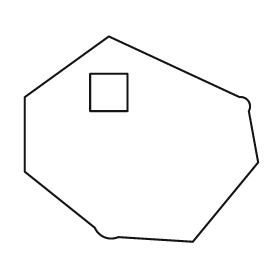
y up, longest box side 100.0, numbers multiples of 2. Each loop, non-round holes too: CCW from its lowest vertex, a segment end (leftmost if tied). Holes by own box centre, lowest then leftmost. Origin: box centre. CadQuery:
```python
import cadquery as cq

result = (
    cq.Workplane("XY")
    .moveTo(22.0, -44.0)
    .lineTo(50.0, -10.0)
    .lineTo(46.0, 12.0)
    .threePointArc((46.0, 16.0), (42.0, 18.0))
    .lineTo(-14.0, 44.0)
    .lineTo(-50.0, 18.0)
    .lineTo(-50.0, -14.0)
    .lineTo(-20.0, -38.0)
    .threePointArc((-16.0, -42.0), (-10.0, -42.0))
    .close()
    .moveTo(-22.0, 12.0)
    .lineTo(-6.0, 12.0)
    .lineTo(-6.0, 28.0)
    .lineTo(-22.0, 28.0)
    .close()
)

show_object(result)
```